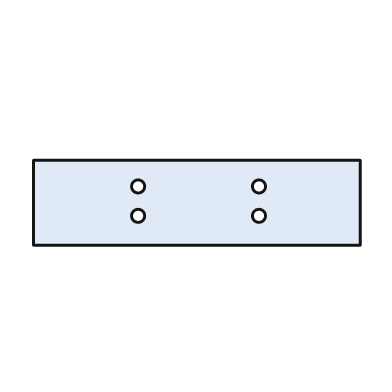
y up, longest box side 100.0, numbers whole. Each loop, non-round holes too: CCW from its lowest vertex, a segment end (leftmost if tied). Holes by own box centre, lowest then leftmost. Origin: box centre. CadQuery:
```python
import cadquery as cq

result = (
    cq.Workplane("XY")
    .moveTo(-50.0, -13.0)
    .lineTo(50.0, -13.0)
    .lineTo(50.0, 13.0)
    .lineTo(-50.0, 13.0)
    .close()
    .moveTo(-18.0, -4.0)
    .circle(2.0)
    .moveTo(19.0, -4.0)
    .circle(2.0)
    .moveTo(-18.0, 5.0)
    .circle(2.0)
    .moveTo(19.0, 5.0)
    .circle(2.0)
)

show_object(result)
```